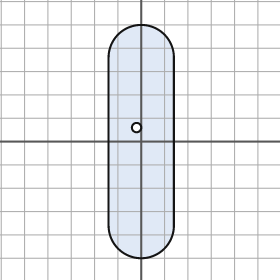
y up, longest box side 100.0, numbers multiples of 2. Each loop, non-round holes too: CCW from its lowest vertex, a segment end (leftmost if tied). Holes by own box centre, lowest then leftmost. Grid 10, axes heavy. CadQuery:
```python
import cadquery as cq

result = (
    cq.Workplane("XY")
    .moveTo(-14.0, -36.0)
    .threePointArc((0.0, -50.0), (14.0, -36.0))
    .lineTo(14.0, 36.0)
    .threePointArc((0.0, 50.0), (-14.0, 36.0))
    .close()
    .moveTo(-2.0, 6.0)
    .circle(2.0)
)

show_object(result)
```